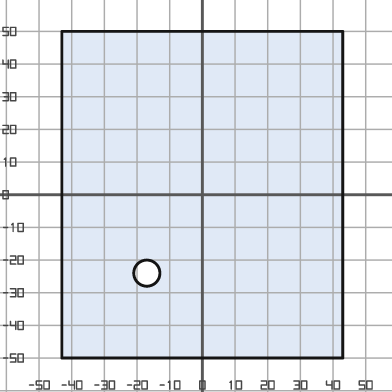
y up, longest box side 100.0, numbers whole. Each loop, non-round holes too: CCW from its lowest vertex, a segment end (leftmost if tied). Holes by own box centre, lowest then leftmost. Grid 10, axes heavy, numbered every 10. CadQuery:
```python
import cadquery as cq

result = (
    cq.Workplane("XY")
    .moveTo(-43.0, -50.0)
    .lineTo(43.0, -50.0)
    .lineTo(43.0, 50.0)
    .lineTo(-43.0, 50.0)
    .close()
    .moveTo(-17.0, -24.0)
    .circle(4.0)
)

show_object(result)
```